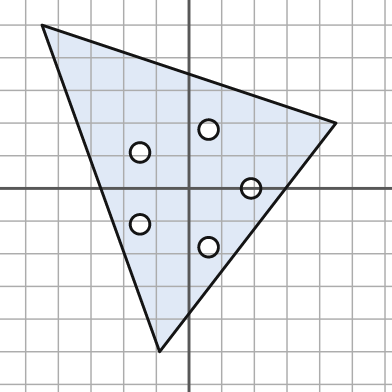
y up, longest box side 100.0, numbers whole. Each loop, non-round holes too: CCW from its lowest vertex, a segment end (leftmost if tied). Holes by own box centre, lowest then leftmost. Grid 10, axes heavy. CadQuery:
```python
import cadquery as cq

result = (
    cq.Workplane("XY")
    .moveTo(-9.0, -50.0)
    .lineTo(45.0, 20.0)
    .lineTo(-45.0, 50.0)
    .close()
    .moveTo(6.0, -18.0)
    .circle(3.0)
    .moveTo(-15.0, -11.0)
    .circle(3.0)
    .moveTo(19.0, 0.0)
    .circle(3.0)
    .moveTo(-15.0, 11.0)
    .circle(3.0)
    .moveTo(6.0, 18.0)
    .circle(3.0)
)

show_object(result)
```